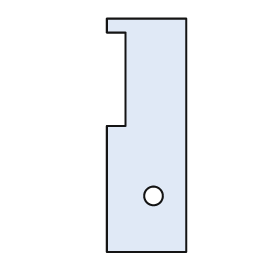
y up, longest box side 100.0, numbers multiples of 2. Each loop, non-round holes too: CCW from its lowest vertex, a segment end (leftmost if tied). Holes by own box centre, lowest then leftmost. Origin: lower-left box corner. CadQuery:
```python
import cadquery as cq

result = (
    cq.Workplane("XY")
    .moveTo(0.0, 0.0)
    .lineTo(34.0, 0.0)
    .lineTo(34.0, 100.0)
    .lineTo(0.0, 100.0)
    .lineTo(0.0, 94.0)
    .lineTo(8.0, 94.0)
    .lineTo(8.0, 54.0)
    .lineTo(0.0, 54.0)
    .close()
    .moveTo(20.0, 24.0)
    .circle(4.0)
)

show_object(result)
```